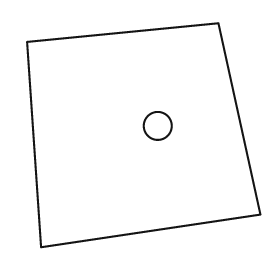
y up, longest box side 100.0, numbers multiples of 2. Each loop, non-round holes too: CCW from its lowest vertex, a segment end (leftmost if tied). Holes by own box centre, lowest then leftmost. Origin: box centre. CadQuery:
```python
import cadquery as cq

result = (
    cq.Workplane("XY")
    .moveTo(-44.0, -48.0)
    .lineTo(50.0, -34.0)
    .lineTo(32.0, 48.0)
    .lineTo(-50.0, 40.0)
    .close()
    .moveTo(6.0, 4.0)
    .circle(6.0)
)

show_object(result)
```